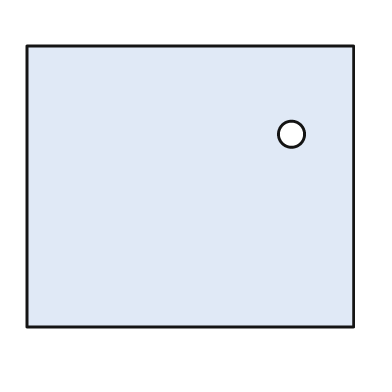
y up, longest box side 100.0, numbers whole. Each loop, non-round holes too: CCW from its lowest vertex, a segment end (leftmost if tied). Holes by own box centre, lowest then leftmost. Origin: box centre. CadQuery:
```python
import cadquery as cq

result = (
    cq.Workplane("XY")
    .moveTo(-50.0, -43.0)
    .lineTo(50.0, -43.0)
    .lineTo(50.0, 43.0)
    .lineTo(-50.0, 43.0)
    .close()
    .moveTo(31.0, 16.0)
    .circle(4.0)
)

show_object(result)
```